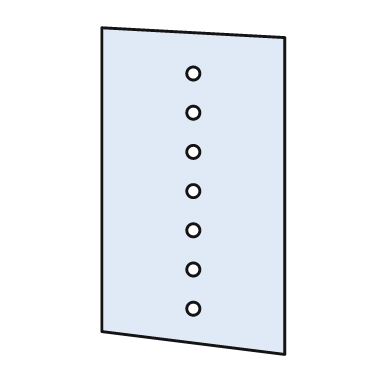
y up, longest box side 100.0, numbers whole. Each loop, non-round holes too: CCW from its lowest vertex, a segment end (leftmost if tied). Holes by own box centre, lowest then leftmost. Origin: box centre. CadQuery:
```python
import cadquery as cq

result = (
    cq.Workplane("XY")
    .moveTo(28.0, -50.0)
    .lineTo(28.0, 47.0)
    .lineTo(-28.0, 50.0)
    .lineTo(-28.0, -43.0)
    .close()
    .moveTo(0.0, -36.0)
    .circle(2.0)
    .moveTo(0.0, -24.0)
    .circle(2.0)
    .moveTo(0.0, -12.0)
    .circle(2.0)
    .moveTo(0.0, 0.0)
    .circle(2.0)
    .moveTo(0.0, 12.0)
    .circle(2.0)
    .moveTo(0.0, 24.0)
    .circle(2.0)
    .moveTo(0.0, 36.0)
    .circle(2.0)
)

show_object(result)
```